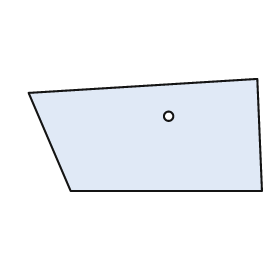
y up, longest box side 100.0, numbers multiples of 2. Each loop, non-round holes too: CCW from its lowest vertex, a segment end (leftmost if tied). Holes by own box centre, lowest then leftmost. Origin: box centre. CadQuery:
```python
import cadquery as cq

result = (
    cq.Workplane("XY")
    .moveTo(-32.0, -24.0)
    .lineTo(50.0, -24.0)
    .lineTo(48.0, 24.0)
    .lineTo(-50.0, 18.0)
    .close()
    .moveTo(10.0, 8.0)
    .circle(2.0)
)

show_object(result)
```